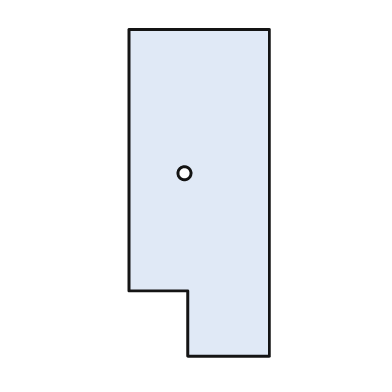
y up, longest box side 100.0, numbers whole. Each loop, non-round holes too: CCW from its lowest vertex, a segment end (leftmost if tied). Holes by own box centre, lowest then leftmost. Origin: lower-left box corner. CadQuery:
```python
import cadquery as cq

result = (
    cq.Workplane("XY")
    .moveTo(18.0, 0.0)
    .lineTo(43.0, 0.0)
    .lineTo(43.0, 100.0)
    .lineTo(0.0, 100.0)
    .lineTo(0.0, 20.0)
    .lineTo(18.0, 20.0)
    .close()
    .moveTo(17.0, 56.0)
    .circle(2.0)
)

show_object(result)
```